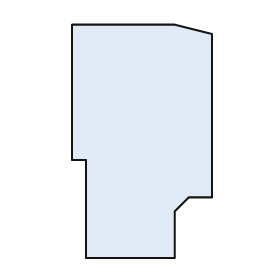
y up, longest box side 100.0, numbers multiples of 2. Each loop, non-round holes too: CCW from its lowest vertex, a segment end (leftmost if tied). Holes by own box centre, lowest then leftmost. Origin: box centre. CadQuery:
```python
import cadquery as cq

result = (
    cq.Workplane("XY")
    .moveTo(-24.0, -50.0)
    .lineTo(14.0, -50.0)
    .lineTo(14.0, -30.0)
    .lineTo(20.0, -24.0)
    .lineTo(30.0, -24.0)
    .lineTo(30.0, 46.0)
    .lineTo(14.0, 50.0)
    .lineTo(-30.0, 50.0)
    .lineTo(-30.0, -8.0)
    .lineTo(-24.0, -8.0)
    .close()
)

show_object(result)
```